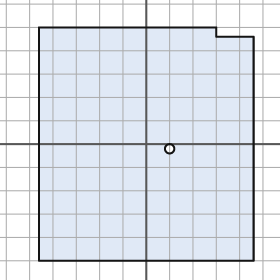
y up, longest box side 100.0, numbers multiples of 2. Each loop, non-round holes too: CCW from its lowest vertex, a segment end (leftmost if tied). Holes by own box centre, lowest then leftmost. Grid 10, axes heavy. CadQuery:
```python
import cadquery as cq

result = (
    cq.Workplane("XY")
    .moveTo(-46.0, -50.0)
    .lineTo(46.0, -50.0)
    .lineTo(46.0, 46.0)
    .lineTo(30.0, 46.0)
    .lineTo(30.0, 50.0)
    .lineTo(-46.0, 50.0)
    .close()
    .moveTo(10.0, -2.0)
    .circle(2.0)
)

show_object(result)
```